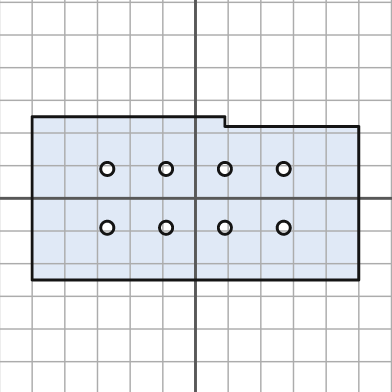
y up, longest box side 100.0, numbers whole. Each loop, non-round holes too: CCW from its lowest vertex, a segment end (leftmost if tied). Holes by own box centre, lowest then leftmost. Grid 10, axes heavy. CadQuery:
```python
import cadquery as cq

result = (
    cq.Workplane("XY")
    .moveTo(-50.0, -25.0)
    .lineTo(50.0, -25.0)
    .lineTo(50.0, 22.0)
    .lineTo(9.0, 22.0)
    .lineTo(9.0, 25.0)
    .lineTo(-50.0, 25.0)
    .close()
    .moveTo(-27.0, -9.0)
    .circle(2.0)
    .moveTo(-9.0, -9.0)
    .circle(2.0)
    .moveTo(9.0, -9.0)
    .circle(2.0)
    .moveTo(27.0, -9.0)
    .circle(2.0)
    .moveTo(-27.0, 9.0)
    .circle(2.0)
    .moveTo(-9.0, 9.0)
    .circle(2.0)
    .moveTo(9.0, 9.0)
    .circle(2.0)
    .moveTo(27.0, 9.0)
    .circle(2.0)
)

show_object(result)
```